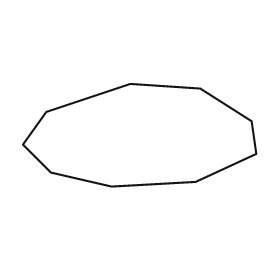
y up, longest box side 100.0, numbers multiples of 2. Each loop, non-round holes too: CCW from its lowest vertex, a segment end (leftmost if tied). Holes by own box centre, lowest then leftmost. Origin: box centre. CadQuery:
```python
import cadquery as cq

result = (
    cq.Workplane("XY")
    .moveTo(-12.0, -22.0)
    .lineTo(24.0, -20.0)
    .lineTo(50.0, -8.0)
    .lineTo(48.0, 6.0)
    .lineTo(26.0, 20.0)
    .lineTo(-4.0, 22.0)
    .lineTo(-40.0, 10.0)
    .lineTo(-50.0, -4.0)
    .lineTo(-38.0, -16.0)
    .close()
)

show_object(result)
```